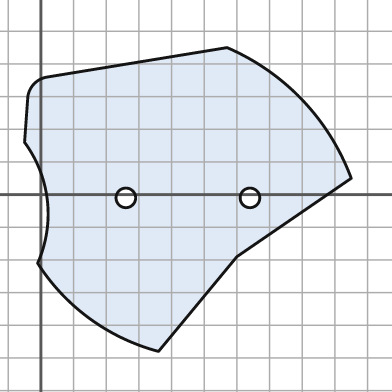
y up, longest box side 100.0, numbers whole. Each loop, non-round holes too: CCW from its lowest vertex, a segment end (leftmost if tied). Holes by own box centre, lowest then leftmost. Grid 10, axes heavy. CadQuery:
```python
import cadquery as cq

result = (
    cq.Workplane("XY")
    .moveTo(36.0, -48.0)
    .lineTo(60.0, -19.0)
    .lineTo(95.0, 5.0)
    .threePointArc((80.0, 29.0), (57.0, 45.0))
    .lineTo(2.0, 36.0)
    .threePointArc((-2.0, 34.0), (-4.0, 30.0))
    .lineTo(-5.0, 16.0)
    .threePointArc((2.0, -2.0), (-1.0, -21.0))
    .threePointArc((15.0, -38.0), (36.0, -48.0))
    .close()
    .moveTo(26.0, -1.0)
    .circle(3.0)
    .moveTo(64.0, -1.0)
    .circle(3.0)
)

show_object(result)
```